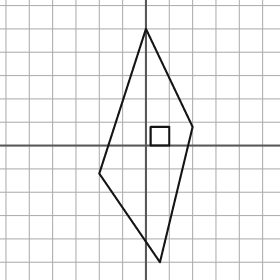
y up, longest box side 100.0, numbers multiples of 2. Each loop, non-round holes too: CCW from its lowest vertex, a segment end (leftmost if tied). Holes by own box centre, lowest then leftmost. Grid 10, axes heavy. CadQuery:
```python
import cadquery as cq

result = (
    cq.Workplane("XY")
    .moveTo(6.0, -50.0)
    .lineTo(20.0, 8.0)
    .lineTo(0.0, 50.0)
    .lineTo(-20.0, -12.0)
    .close()
    .moveTo(2.0, 0.0)
    .lineTo(10.0, 0.0)
    .lineTo(10.0, 8.0)
    .lineTo(2.0, 8.0)
    .close()
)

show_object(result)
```